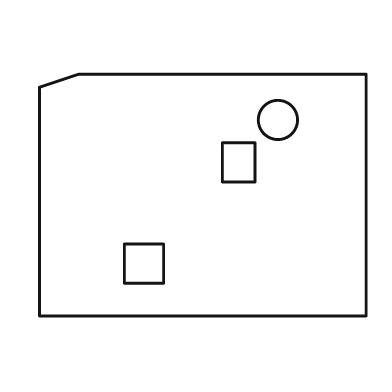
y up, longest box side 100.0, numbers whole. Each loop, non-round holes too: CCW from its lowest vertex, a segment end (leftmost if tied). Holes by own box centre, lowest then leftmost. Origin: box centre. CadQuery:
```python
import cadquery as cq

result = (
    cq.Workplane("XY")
    .moveTo(-50.0, -37.0)
    .lineTo(50.0, -37.0)
    .lineTo(50.0, 37.0)
    .lineTo(-38.0, 37.0)
    .lineTo(-50.0, 33.0)
    .close()
    .moveTo(-24.0, -27.0)
    .lineTo(-12.0, -27.0)
    .lineTo(-12.0, -15.0)
    .lineTo(-24.0, -15.0)
    .close()
    .moveTo(6.0, 4.0)
    .lineTo(16.0, 4.0)
    .lineTo(16.0, 16.0)
    .lineTo(6.0, 16.0)
    .close()
    .moveTo(23.0, 23.0)
    .circle(6.0)
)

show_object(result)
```